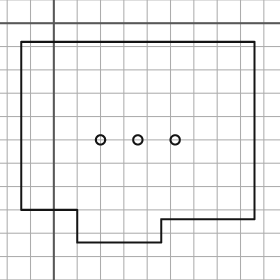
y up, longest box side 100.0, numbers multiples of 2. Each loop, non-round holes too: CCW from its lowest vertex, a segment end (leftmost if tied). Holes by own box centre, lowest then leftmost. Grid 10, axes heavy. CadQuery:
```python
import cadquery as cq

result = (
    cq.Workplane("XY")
    .moveTo(10.0, -94.0)
    .lineTo(46.0, -94.0)
    .lineTo(46.0, -84.0)
    .lineTo(86.0, -84.0)
    .lineTo(86.0, -8.0)
    .lineTo(-14.0, -8.0)
    .lineTo(-14.0, -80.0)
    .lineTo(10.0, -80.0)
    .close()
    .moveTo(20.0, -50.0)
    .circle(2.0)
    .moveTo(36.0, -50.0)
    .circle(2.0)
    .moveTo(52.0, -50.0)
    .circle(2.0)
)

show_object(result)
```